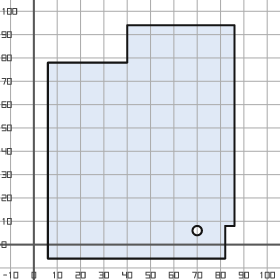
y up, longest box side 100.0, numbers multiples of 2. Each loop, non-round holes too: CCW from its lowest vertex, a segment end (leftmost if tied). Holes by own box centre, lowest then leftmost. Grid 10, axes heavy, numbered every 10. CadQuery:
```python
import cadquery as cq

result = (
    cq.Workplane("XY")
    .moveTo(6.0, -6.0)
    .lineTo(82.0, -6.0)
    .lineTo(82.0, 8.0)
    .lineTo(86.0, 8.0)
    .lineTo(86.0, 94.0)
    .lineTo(40.0, 94.0)
    .lineTo(40.0, 78.0)
    .lineTo(6.0, 78.0)
    .close()
    .moveTo(70.0, 6.0)
    .circle(2.0)
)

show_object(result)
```